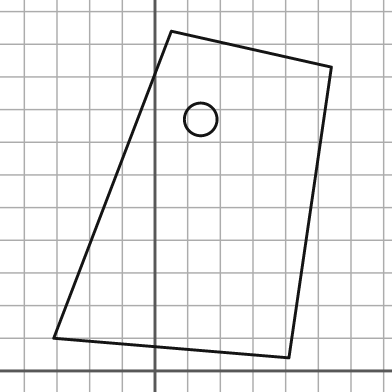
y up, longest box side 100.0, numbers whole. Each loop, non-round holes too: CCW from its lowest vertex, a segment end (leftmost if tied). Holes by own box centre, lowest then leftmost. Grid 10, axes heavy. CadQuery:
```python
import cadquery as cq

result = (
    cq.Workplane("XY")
    .moveTo(41.0, 4.0)
    .lineTo(54.0, 93.0)
    .lineTo(5.0, 104.0)
    .lineTo(-31.0, 10.0)
    .close()
    .moveTo(14.0, 77.0)
    .circle(5.0)
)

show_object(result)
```